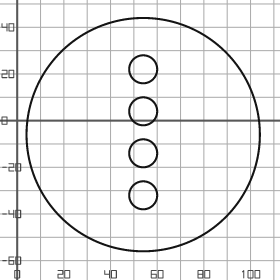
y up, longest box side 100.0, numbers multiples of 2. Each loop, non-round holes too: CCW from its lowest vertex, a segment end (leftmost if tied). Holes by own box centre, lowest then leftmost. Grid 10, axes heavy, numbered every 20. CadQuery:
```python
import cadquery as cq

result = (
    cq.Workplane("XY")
    .moveTo(54.0, -6.0)
    .circle(50.0)
    .moveTo(54.0, -32.0)
    .circle(6.0)
    .moveTo(54.0, -14.0)
    .circle(6.0)
    .moveTo(54.0, 4.0)
    .circle(6.0)
    .moveTo(54.0, 22.0)
    .circle(6.0)
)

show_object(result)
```